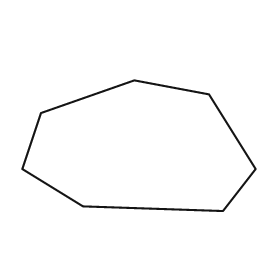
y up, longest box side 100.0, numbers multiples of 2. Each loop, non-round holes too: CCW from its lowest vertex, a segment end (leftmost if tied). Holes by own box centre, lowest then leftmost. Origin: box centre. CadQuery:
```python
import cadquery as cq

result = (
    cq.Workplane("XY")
    .moveTo(36.0, -28.0)
    .lineTo(50.0, -10.0)
    .lineTo(30.0, 22.0)
    .lineTo(-2.0, 28.0)
    .lineTo(-42.0, 14.0)
    .lineTo(-50.0, -10.0)
    .lineTo(-24.0, -26.0)
    .close()
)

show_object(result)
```